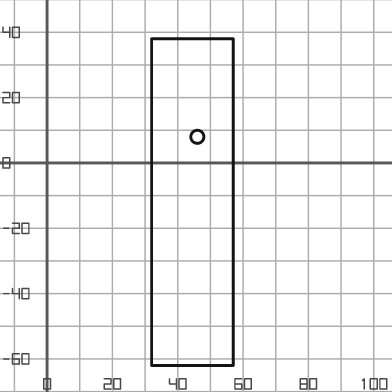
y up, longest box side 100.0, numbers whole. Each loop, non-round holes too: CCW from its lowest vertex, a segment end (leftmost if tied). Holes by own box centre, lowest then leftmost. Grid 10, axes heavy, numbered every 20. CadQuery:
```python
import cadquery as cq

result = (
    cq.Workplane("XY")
    .moveTo(32.0, -62.0)
    .lineTo(57.0, -62.0)
    .lineTo(57.0, 38.0)
    .lineTo(32.0, 38.0)
    .close()
    .moveTo(46.0, 8.0)
    .circle(2.0)
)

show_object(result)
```